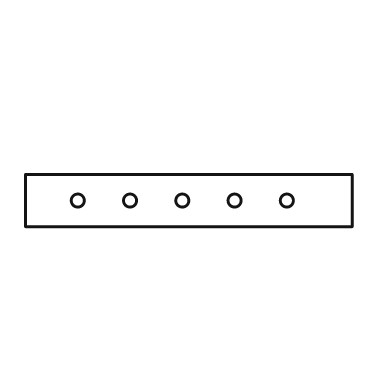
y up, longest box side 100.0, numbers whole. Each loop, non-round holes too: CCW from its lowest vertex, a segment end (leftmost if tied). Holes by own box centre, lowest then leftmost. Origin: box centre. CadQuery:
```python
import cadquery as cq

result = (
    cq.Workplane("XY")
    .moveTo(-50.0, -8.0)
    .lineTo(50.0, -8.0)
    .lineTo(50.0, 8.0)
    .lineTo(-50.0, 8.0)
    .close()
    .moveTo(-34.0, 0.0)
    .circle(2.0)
    .moveTo(-18.0, 0.0)
    .circle(2.0)
    .moveTo(-2.0, 0.0)
    .circle(2.0)
    .moveTo(14.0, 0.0)
    .circle(2.0)
    .moveTo(30.0, 0.0)
    .circle(2.0)
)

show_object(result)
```